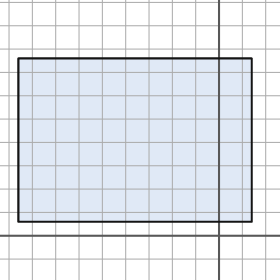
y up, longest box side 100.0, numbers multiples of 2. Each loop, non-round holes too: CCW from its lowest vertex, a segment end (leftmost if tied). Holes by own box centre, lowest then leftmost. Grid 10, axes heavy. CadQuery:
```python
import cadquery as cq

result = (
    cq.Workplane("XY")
    .moveTo(-86.0, 6.0)
    .lineTo(14.0, 6.0)
    .lineTo(14.0, 76.0)
    .lineTo(-86.0, 76.0)
    .close()
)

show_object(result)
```